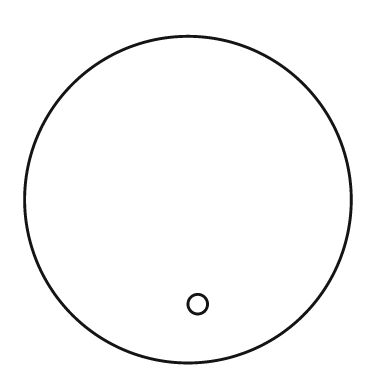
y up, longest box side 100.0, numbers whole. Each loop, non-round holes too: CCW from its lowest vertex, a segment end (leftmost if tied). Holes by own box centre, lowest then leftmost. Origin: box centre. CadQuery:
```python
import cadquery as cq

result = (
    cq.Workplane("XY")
    .moveTo(0.0, 0.0)
    .circle(50.0)
    .moveTo(3.0, -32.0)
    .circle(3.0)
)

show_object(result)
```